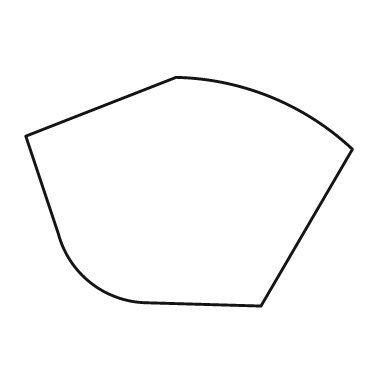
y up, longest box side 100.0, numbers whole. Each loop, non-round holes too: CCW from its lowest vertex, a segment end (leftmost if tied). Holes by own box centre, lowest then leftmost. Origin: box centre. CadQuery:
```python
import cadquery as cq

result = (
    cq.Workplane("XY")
    .moveTo(22.0, -35.0)
    .lineTo(50.0, 13.0)
    .threePointArc((25.0, 29.0), (-4.0, 35.0))
    .lineTo(-50.0, 17.0)
    .lineTo(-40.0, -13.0)
    .threePointArc((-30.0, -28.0), (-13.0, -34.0))
    .close()
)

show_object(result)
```